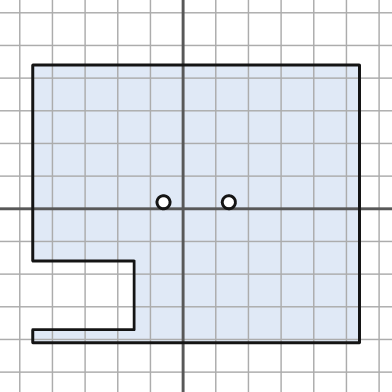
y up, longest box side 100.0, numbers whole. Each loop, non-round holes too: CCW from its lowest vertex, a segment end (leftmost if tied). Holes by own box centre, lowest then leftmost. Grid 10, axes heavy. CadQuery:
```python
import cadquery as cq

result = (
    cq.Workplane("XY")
    .moveTo(-46.0, -41.0)
    .lineTo(54.0, -41.0)
    .lineTo(54.0, 44.0)
    .lineTo(-46.0, 44.0)
    .lineTo(-46.0, -16.0)
    .lineTo(-15.0, -16.0)
    .lineTo(-15.0, -37.0)
    .lineTo(-46.0, -37.0)
    .close()
    .moveTo(-6.0, 2.0)
    .circle(2.0)
    .moveTo(14.0, 2.0)
    .circle(2.0)
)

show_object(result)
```